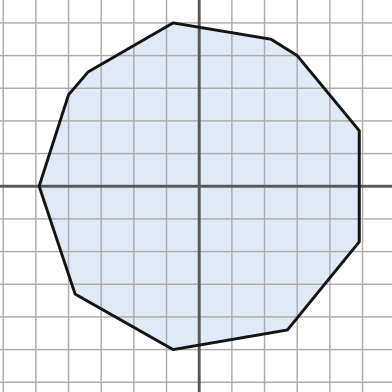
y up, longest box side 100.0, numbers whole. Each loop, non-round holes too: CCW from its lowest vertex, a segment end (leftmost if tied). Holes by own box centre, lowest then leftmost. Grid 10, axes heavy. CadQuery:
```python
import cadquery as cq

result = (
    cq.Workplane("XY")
    .moveTo(-8.0, -50.0)
    .lineTo(27.0, -44.0)
    .lineTo(49.0, -17.0)
    .lineTo(49.0, 17.0)
    .lineTo(30.0, 40.0)
    .lineTo(22.0, 45.0)
    .lineTo(-8.0, 50.0)
    .lineTo(-34.0, 35.0)
    .lineTo(-40.0, 28.0)
    .lineTo(-49.0, 0.0)
    .lineTo(-38.0, -33.0)
    .close()
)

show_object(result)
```